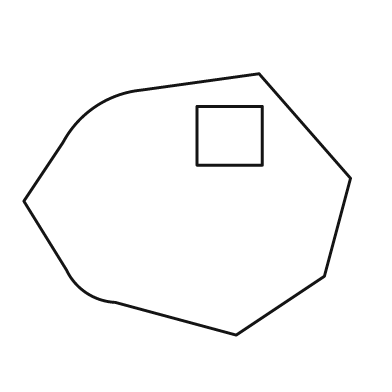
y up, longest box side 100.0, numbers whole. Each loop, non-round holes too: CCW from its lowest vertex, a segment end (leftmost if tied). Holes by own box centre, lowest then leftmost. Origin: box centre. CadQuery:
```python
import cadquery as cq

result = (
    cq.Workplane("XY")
    .moveTo(15.0, -40.0)
    .lineTo(42.0, -22.0)
    .lineTo(50.0, 8.0)
    .lineTo(22.0, 40.0)
    .lineTo(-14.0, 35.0)
    .threePointArc((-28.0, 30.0), (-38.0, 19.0))
    .lineTo(-50.0, 1.0)
    .lineTo(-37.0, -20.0)
    .threePointArc((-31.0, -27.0), (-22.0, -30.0))
    .close()
    .moveTo(3.0, 12.0)
    .lineTo(23.0, 12.0)
    .lineTo(23.0, 30.0)
    .lineTo(3.0, 30.0)
    .close()
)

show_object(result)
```